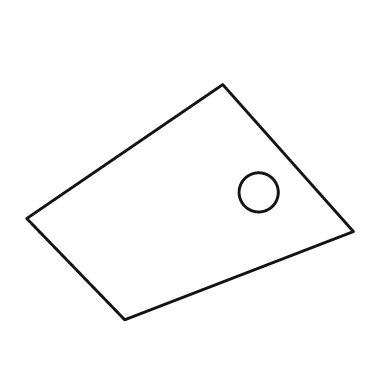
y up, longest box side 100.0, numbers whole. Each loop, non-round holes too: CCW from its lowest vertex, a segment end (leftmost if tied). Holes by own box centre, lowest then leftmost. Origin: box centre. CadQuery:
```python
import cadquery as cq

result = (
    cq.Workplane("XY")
    .moveTo(-20.0, -36.0)
    .lineTo(50.0, -9.0)
    .lineTo(10.0, 36.0)
    .lineTo(-50.0, -5.0)
    .close()
    .moveTo(21.0, 3.0)
    .circle(6.0)
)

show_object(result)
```